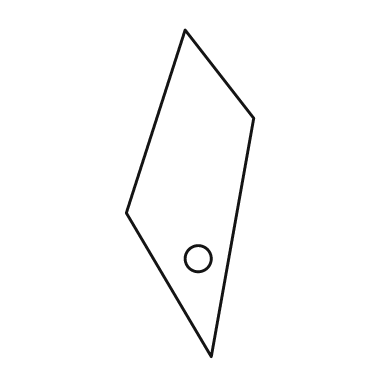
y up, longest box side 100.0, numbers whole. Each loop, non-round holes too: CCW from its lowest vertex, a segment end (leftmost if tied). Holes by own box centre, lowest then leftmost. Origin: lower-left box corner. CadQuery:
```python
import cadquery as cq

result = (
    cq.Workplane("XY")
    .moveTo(26.0, 0.0)
    .lineTo(39.0, 73.0)
    .lineTo(18.0, 100.0)
    .lineTo(0.0, 44.0)
    .close()
    .moveTo(22.0, 30.0)
    .circle(4.0)
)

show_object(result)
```